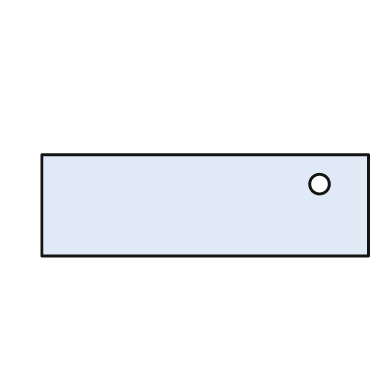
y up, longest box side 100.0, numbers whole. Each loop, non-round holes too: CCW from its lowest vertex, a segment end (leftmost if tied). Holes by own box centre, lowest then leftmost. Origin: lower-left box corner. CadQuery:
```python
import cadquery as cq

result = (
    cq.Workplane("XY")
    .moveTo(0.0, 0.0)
    .lineTo(100.0, 0.0)
    .lineTo(100.0, 31.0)
    .lineTo(0.0, 31.0)
    .close()
    .moveTo(85.0, 22.0)
    .circle(3.0)
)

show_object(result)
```